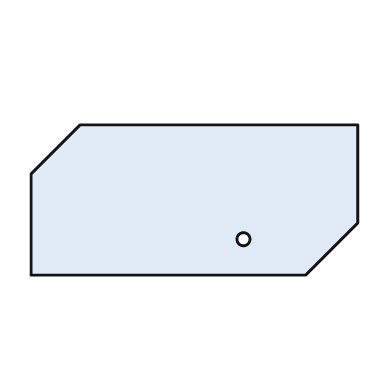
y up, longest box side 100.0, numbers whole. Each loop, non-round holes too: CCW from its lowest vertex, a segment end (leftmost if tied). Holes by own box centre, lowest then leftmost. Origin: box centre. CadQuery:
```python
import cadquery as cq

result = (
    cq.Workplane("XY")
    .moveTo(-50.0, -23.0)
    .lineTo(34.0, -23.0)
    .lineTo(50.0, -7.0)
    .lineTo(50.0, 23.0)
    .lineTo(-35.0, 23.0)
    .lineTo(-50.0, 8.0)
    .close()
    .moveTo(15.0, -12.0)
    .circle(2.0)
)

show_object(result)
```